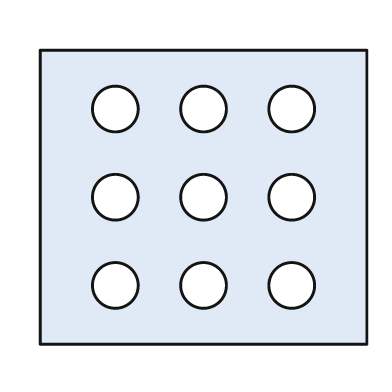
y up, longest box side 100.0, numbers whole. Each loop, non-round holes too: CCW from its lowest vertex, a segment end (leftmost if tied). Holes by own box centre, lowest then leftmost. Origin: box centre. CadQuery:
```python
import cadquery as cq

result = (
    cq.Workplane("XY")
    .moveTo(-50.0, -45.0)
    .lineTo(50.0, -45.0)
    .lineTo(50.0, 45.0)
    .lineTo(-50.0, 45.0)
    .close()
    .moveTo(-27.0, -27.0)
    .circle(7.0)
    .moveTo(0.0, -27.0)
    .circle(7.0)
    .moveTo(27.0, -27.0)
    .circle(7.0)
    .moveTo(-27.0, 0.0)
    .circle(7.0)
    .moveTo(0.0, 0.0)
    .circle(7.0)
    .moveTo(27.0, 0.0)
    .circle(7.0)
    .moveTo(-27.0, 27.0)
    .circle(7.0)
    .moveTo(0.0, 27.0)
    .circle(7.0)
    .moveTo(27.0, 27.0)
    .circle(7.0)
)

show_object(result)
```